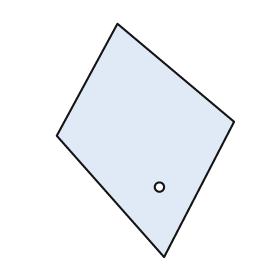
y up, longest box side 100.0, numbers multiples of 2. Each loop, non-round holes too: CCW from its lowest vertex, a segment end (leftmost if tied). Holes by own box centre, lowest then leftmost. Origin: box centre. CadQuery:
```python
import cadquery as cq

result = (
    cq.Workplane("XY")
    .moveTo(8.0, -50.0)
    .lineTo(38.0, 8.0)
    .lineTo(-12.0, 50.0)
    .lineTo(-38.0, 2.0)
    .close()
    .moveTo(6.0, -20.0)
    .circle(2.0)
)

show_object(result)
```